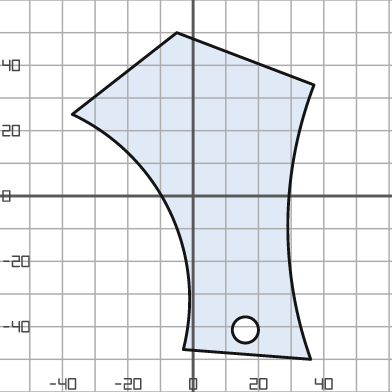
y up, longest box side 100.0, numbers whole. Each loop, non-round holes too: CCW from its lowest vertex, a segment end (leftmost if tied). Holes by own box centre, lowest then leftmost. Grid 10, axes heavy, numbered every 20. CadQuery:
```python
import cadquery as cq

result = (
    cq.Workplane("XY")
    .moveTo(36.0, -50.0)
    .threePointArc((29.0, -8.0), (37.0, 34.0))
    .lineTo(-5.0, 50.0)
    .lineTo(-37.0, 25.0)
    .threePointArc((-7.0, -5.0), (-3.0, -47.0))
    .close()
    .moveTo(16.0, -41.0)
    .circle(4.0)
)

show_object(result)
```